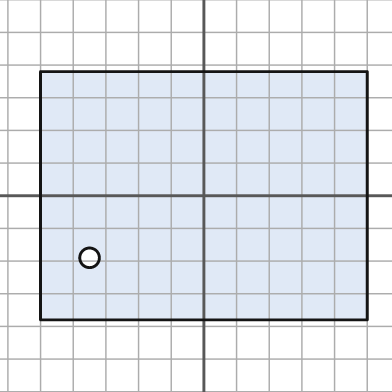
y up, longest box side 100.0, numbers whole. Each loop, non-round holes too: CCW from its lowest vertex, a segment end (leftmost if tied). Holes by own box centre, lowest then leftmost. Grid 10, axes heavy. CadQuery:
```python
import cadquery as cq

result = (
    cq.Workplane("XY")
    .moveTo(-50.0, -38.0)
    .lineTo(50.0, -38.0)
    .lineTo(50.0, 38.0)
    .lineTo(-50.0, 38.0)
    .close()
    .moveTo(-35.0, -19.0)
    .circle(3.0)
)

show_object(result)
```